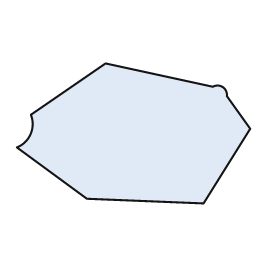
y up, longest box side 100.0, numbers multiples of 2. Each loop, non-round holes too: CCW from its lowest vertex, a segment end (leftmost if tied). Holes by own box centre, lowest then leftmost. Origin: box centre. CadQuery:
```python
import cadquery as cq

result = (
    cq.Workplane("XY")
    .moveTo(30.0, -30.0)
    .lineTo(50.0, 2.0)
    .lineTo(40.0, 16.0)
    .threePointArc((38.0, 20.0), (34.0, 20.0))
    .lineTo(-12.0, 30.0)
    .lineTo(-44.0, 8.0)
    .threePointArc((-44.0, 0.0), (-50.0, -6.0))
    .lineTo(-20.0, -28.0)
    .close()
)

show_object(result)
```